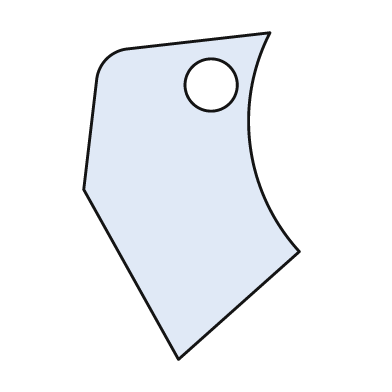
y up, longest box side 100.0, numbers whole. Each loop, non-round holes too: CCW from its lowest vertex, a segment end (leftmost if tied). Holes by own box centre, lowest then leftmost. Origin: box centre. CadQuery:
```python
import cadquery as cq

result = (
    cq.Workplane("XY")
    .moveTo(-4.0, -50.0)
    .lineTo(33.0, -17.0)
    .threePointArc((18.0, 15.0), (24.0, 50.0))
    .lineTo(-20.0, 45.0)
    .threePointArc((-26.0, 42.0), (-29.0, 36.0))
    .lineTo(-33.0, 2.0)
    .close()
    .moveTo(6.0, 34.0)
    .circle(8.0)
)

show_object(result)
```